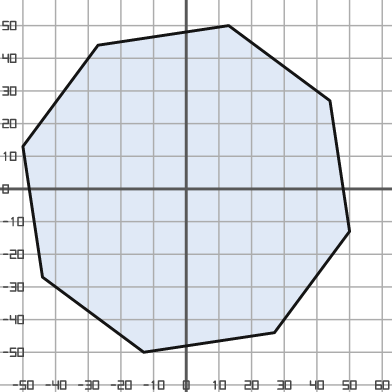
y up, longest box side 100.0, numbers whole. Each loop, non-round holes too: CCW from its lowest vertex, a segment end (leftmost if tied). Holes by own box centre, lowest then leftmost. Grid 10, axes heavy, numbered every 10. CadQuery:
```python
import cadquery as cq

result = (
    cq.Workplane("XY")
    .moveTo(-13.0, -50.0)
    .lineTo(27.0, -44.0)
    .lineTo(50.0, -13.0)
    .lineTo(44.0, 27.0)
    .lineTo(13.0, 50.0)
    .lineTo(-27.0, 44.0)
    .lineTo(-50.0, 13.0)
    .lineTo(-44.0, -27.0)
    .close()
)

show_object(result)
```